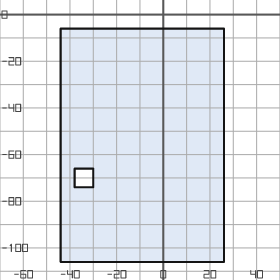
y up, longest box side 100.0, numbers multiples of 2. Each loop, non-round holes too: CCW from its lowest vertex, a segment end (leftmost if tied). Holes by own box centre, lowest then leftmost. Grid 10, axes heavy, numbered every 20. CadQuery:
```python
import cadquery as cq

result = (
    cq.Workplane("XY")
    .moveTo(-44.0, -106.0)
    .lineTo(26.0, -106.0)
    .lineTo(26.0, -6.0)
    .lineTo(-44.0, -6.0)
    .close()
    .moveTo(-38.0, -74.0)
    .lineTo(-30.0, -74.0)
    .lineTo(-30.0, -66.0)
    .lineTo(-38.0, -66.0)
    .close()
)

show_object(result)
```